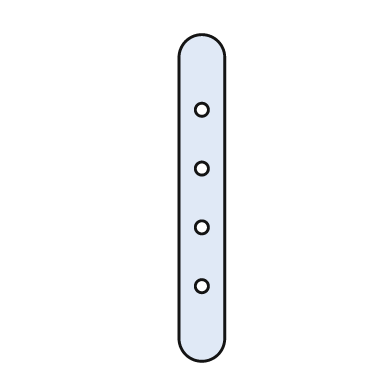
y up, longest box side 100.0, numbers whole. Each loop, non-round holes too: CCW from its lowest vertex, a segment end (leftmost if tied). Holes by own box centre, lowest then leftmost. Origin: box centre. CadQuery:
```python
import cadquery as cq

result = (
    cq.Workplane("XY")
    .moveTo(-7.0, -43.0)
    .threePointArc((0.0, -50.0), (7.0, -43.0))
    .lineTo(7.0, 43.0)
    .threePointArc((0.0, 50.0), (-7.0, 43.0))
    .close()
    .moveTo(0.0, -27.0)
    .circle(2.0)
    .moveTo(0.0, -9.0)
    .circle(2.0)
    .moveTo(0.0, 9.0)
    .circle(2.0)
    .moveTo(0.0, 27.0)
    .circle(2.0)
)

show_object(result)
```